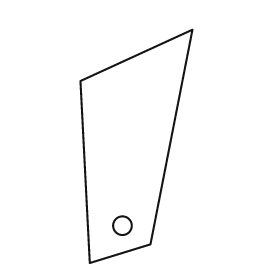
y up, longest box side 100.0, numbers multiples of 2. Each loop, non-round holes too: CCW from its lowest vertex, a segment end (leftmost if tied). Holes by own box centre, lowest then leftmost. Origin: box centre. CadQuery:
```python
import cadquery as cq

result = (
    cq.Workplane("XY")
    .moveTo(-20.0, -50.0)
    .lineTo(6.0, -42.0)
    .lineTo(24.0, 50.0)
    .lineTo(-24.0, 28.0)
    .close()
    .moveTo(-6.0, -34.0)
    .circle(4.0)
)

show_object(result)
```